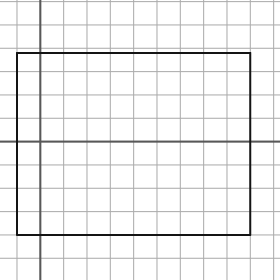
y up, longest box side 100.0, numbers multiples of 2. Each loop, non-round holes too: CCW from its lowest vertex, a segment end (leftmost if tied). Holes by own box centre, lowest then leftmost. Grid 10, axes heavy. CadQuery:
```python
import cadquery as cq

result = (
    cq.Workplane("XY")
    .moveTo(-10.0, -40.0)
    .lineTo(90.0, -40.0)
    .lineTo(90.0, 38.0)
    .lineTo(-10.0, 38.0)
    .close()
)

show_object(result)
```